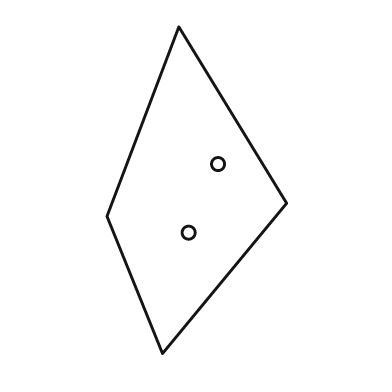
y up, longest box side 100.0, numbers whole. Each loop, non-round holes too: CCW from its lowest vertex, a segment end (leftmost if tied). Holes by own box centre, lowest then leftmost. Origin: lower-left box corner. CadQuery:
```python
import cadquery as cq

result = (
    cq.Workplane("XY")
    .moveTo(17.0, 0.0)
    .lineTo(55.0, 46.0)
    .lineTo(22.0, 100.0)
    .lineTo(0.0, 42.0)
    .close()
    .moveTo(25.0, 37.0)
    .circle(2.0)
    .moveTo(34.0, 58.0)
    .circle(2.0)
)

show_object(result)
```